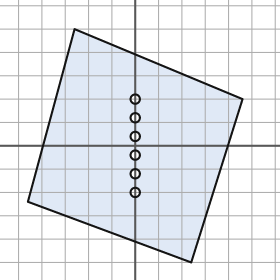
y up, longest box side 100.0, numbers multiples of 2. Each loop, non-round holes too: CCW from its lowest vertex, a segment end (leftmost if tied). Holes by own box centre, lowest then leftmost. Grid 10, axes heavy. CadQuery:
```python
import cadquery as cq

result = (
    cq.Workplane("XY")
    .moveTo(24.0, -50.0)
    .lineTo(46.0, 20.0)
    .lineTo(-26.0, 50.0)
    .lineTo(-46.0, -24.0)
    .close()
    .moveTo(0.0, -20.0)
    .circle(2.0)
    .moveTo(0.0, -12.0)
    .circle(2.0)
    .moveTo(0.0, -4.0)
    .circle(2.0)
    .moveTo(0.0, 4.0)
    .circle(2.0)
    .moveTo(0.0, 12.0)
    .circle(2.0)
    .moveTo(0.0, 20.0)
    .circle(2.0)
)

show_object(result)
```